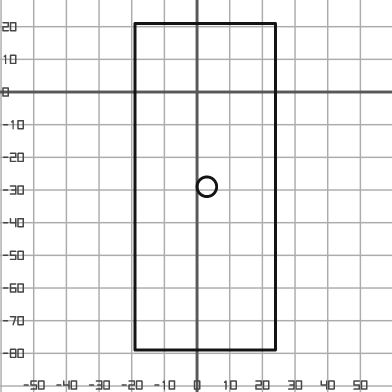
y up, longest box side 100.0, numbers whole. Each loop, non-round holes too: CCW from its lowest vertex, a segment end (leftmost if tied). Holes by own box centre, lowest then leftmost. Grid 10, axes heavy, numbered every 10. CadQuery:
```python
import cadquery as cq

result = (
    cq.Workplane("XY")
    .moveTo(-19.0, -79.0)
    .lineTo(24.0, -79.0)
    .lineTo(24.0, 21.0)
    .lineTo(-19.0, 21.0)
    .close()
    .moveTo(3.0, -29.0)
    .circle(3.0)
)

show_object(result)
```